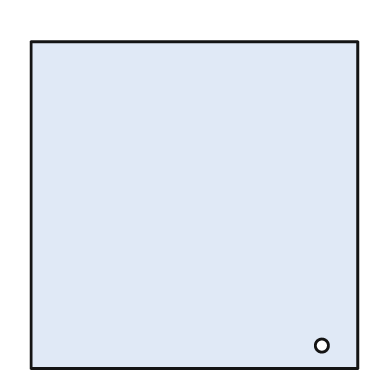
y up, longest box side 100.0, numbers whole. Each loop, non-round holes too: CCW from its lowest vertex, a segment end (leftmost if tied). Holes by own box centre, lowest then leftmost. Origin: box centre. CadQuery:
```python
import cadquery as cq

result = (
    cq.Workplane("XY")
    .moveTo(-50.0, -50.0)
    .lineTo(50.0, -50.0)
    .lineTo(50.0, 50.0)
    .lineTo(-50.0, 50.0)
    .close()
    .moveTo(39.0, -43.0)
    .circle(2.0)
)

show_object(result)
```